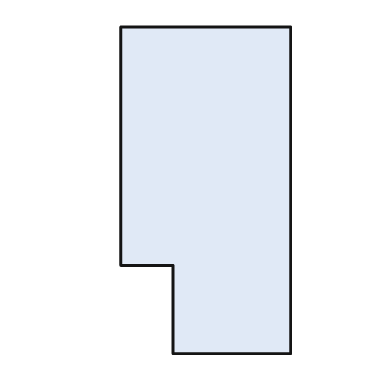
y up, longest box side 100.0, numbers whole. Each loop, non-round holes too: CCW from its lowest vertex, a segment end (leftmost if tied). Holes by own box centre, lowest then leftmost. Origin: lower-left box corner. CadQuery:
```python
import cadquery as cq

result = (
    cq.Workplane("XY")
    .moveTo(16.0, 0.0)
    .lineTo(52.0, 0.0)
    .lineTo(52.0, 100.0)
    .lineTo(0.0, 100.0)
    .lineTo(0.0, 27.0)
    .lineTo(16.0, 27.0)
    .close()
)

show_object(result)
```